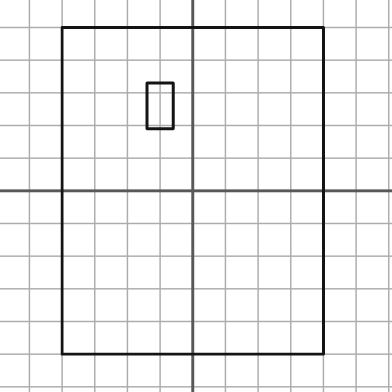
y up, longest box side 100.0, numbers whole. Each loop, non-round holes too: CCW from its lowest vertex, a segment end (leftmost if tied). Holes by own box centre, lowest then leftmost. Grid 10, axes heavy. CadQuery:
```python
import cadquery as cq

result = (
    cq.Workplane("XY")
    .moveTo(-40.0, -50.0)
    .lineTo(40.0, -50.0)
    .lineTo(40.0, 50.0)
    .lineTo(-40.0, 50.0)
    .close()
    .moveTo(-14.0, 19.0)
    .lineTo(-6.0, 19.0)
    .lineTo(-6.0, 33.0)
    .lineTo(-14.0, 33.0)
    .close()
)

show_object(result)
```